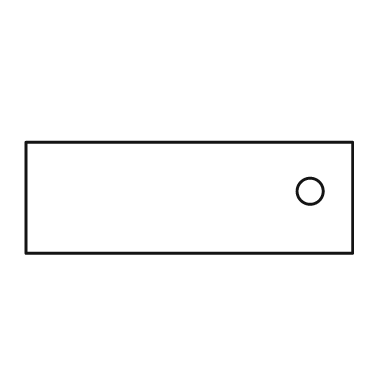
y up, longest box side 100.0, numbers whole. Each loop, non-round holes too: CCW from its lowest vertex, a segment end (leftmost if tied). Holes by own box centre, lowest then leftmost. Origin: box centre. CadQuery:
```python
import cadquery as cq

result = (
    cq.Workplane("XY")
    .moveTo(-50.0, -17.0)
    .lineTo(50.0, -17.0)
    .lineTo(50.0, 17.0)
    .lineTo(-50.0, 17.0)
    .close()
    .moveTo(37.0, 2.0)
    .circle(4.0)
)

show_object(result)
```